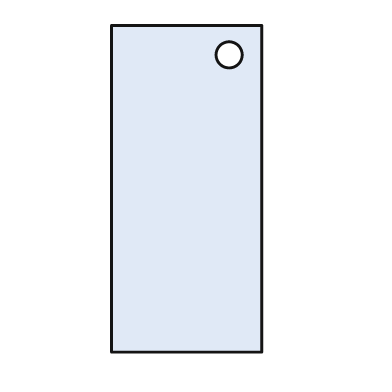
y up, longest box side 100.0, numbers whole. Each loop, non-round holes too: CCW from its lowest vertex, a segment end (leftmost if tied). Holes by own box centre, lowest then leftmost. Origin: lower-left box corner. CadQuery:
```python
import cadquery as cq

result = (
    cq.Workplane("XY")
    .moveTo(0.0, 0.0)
    .lineTo(46.0, 0.0)
    .lineTo(46.0, 100.0)
    .lineTo(0.0, 100.0)
    .close()
    .moveTo(36.0, 91.0)
    .circle(4.0)
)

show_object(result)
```